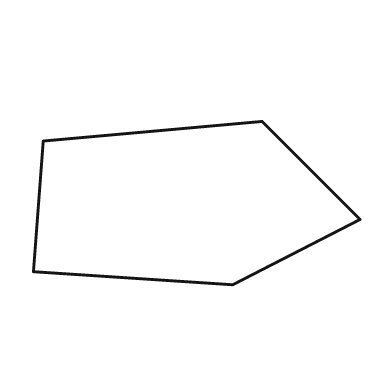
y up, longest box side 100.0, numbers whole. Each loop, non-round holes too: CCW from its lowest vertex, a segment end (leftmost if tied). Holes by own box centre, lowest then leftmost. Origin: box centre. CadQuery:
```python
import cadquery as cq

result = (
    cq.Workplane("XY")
    .moveTo(11.0, -25.0)
    .lineTo(50.0, -5.0)
    .lineTo(20.0, 25.0)
    .lineTo(-47.0, 19.0)
    .lineTo(-50.0, -21.0)
    .close()
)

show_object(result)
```